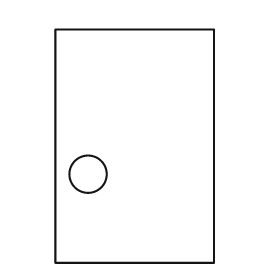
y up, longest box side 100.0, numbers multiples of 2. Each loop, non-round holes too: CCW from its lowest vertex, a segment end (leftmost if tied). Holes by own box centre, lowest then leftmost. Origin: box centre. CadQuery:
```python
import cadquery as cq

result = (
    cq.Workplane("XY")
    .moveTo(-34.0, -50.0)
    .lineTo(34.0, -50.0)
    .lineTo(34.0, 50.0)
    .lineTo(-34.0, 50.0)
    .close()
    .moveTo(-20.0, -12.0)
    .circle(8.0)
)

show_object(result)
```